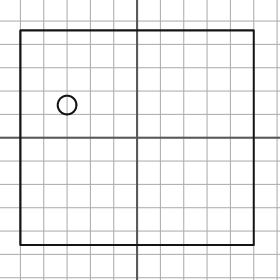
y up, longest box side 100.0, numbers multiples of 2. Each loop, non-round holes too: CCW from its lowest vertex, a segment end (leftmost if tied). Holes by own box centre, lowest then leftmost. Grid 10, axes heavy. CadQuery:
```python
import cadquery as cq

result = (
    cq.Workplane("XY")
    .moveTo(-50.0, -46.0)
    .lineTo(50.0, -46.0)
    .lineTo(50.0, 46.0)
    .lineTo(-50.0, 46.0)
    .close()
    .moveTo(-30.0, 14.0)
    .circle(4.0)
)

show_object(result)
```